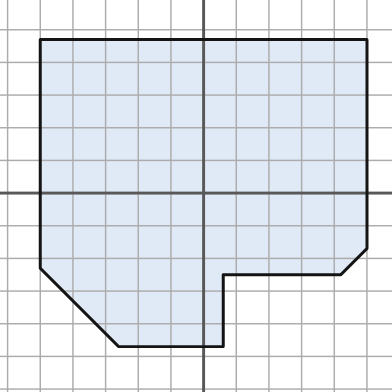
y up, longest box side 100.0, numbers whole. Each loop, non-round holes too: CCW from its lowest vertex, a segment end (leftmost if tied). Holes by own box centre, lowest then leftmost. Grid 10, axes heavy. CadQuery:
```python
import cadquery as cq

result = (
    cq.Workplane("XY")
    .moveTo(-26.0, -47.0)
    .lineTo(6.0, -47.0)
    .lineTo(6.0, -25.0)
    .lineTo(42.0, -25.0)
    .lineTo(50.0, -17.0)
    .lineTo(50.0, 47.0)
    .lineTo(-50.0, 47.0)
    .lineTo(-50.0, -23.0)
    .close()
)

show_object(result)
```